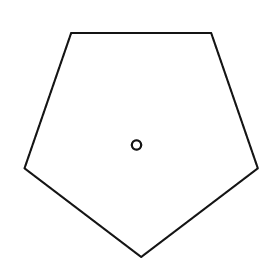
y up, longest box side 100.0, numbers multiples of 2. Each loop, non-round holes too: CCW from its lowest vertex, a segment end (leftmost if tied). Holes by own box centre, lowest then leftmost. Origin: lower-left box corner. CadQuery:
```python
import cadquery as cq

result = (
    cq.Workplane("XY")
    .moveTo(50.0, 0.0)
    .lineTo(100.0, 38.0)
    .lineTo(80.0, 96.0)
    .lineTo(20.0, 96.0)
    .lineTo(0.0, 38.0)
    .close()
    .moveTo(48.0, 48.0)
    .circle(2.0)
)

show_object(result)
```